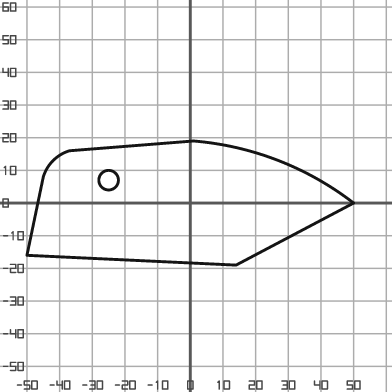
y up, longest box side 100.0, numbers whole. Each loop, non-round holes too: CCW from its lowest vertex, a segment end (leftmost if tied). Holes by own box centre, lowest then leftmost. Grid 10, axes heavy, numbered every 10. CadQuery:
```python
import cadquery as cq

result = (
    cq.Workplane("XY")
    .moveTo(14.0, -19.0)
    .lineTo(50.0, 0.0)
    .threePointArc((27.0, 13.0), (1.0, 19.0))
    .lineTo(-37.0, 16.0)
    .threePointArc((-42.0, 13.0), (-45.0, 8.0))
    .lineTo(-50.0, -16.0)
    .close()
    .moveTo(-25.0, 7.0)
    .circle(3.0)
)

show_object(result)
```